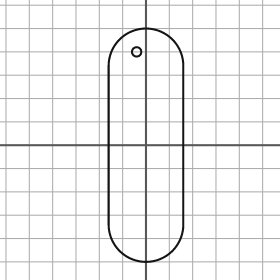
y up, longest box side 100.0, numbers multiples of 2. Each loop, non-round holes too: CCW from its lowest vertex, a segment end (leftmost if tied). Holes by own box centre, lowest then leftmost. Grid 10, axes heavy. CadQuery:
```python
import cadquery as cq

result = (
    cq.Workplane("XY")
    .moveTo(-16.0, -34.0)
    .threePointArc((0.0, -50.0), (16.0, -34.0))
    .lineTo(16.0, 34.0)
    .threePointArc((0.0, 50.0), (-16.0, 34.0))
    .close()
    .moveTo(-4.0, 40.0)
    .circle(2.0)
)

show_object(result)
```